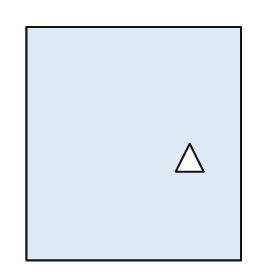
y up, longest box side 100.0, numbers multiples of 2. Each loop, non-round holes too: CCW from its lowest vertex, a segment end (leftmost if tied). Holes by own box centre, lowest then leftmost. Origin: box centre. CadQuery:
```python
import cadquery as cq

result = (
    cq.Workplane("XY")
    .moveTo(-46.0, -50.0)
    .lineTo(46.0, -50.0)
    .lineTo(46.0, 50.0)
    .lineTo(-46.0, 50.0)
    .close()
    .moveTo(18.0, -12.0)
    .lineTo(30.0, -12.0)
    .lineTo(24.0, 0.0)
    .close()
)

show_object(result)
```